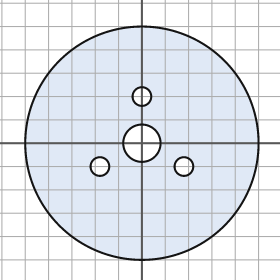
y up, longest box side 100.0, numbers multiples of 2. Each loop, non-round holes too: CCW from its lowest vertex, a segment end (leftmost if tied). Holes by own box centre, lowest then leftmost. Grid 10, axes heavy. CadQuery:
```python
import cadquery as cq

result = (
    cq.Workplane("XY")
    .moveTo(0.0, 0.0)
    .circle(50.0)
    .moveTo(-18.0, -10.0)
    .circle(4.0)
    .moveTo(18.0, -10.0)
    .circle(4.0)
    .moveTo(0.0, 0.0)
    .circle(8.0)
    .moveTo(0.0, 20.0)
    .circle(4.0)
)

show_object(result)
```